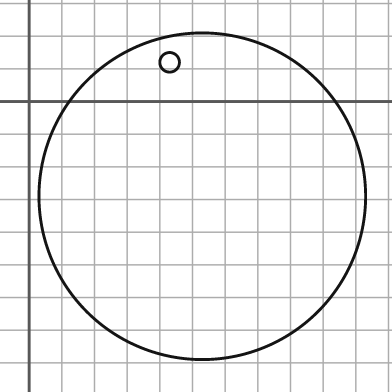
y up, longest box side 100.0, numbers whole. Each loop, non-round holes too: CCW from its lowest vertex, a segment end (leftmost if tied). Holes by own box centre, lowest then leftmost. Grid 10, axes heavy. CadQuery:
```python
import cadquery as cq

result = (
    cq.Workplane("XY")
    .moveTo(53.0, -29.0)
    .circle(50.0)
    .moveTo(43.0, 12.0)
    .circle(3.0)
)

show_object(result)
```